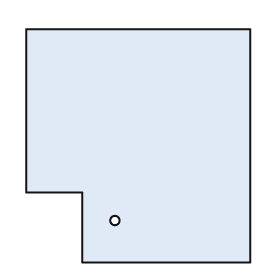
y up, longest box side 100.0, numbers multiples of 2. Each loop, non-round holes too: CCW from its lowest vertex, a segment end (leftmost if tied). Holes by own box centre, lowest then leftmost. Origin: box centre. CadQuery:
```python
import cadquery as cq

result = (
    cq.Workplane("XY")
    .moveTo(-24.0, -50.0)
    .lineTo(48.0, -50.0)
    .lineTo(48.0, 50.0)
    .lineTo(-48.0, 50.0)
    .lineTo(-48.0, -20.0)
    .lineTo(-24.0, -20.0)
    .close()
    .moveTo(-10.0, -32.0)
    .circle(2.0)
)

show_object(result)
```